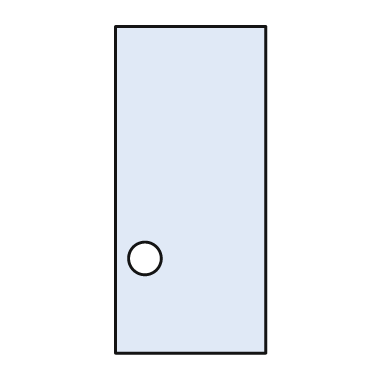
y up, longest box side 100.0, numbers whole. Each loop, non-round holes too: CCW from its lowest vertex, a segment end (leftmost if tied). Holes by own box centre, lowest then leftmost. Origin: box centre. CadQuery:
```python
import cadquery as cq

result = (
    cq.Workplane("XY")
    .moveTo(-23.0, -50.0)
    .lineTo(23.0, -50.0)
    .lineTo(23.0, 50.0)
    .lineTo(-23.0, 50.0)
    .close()
    .moveTo(-14.0, -21.0)
    .circle(5.0)
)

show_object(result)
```